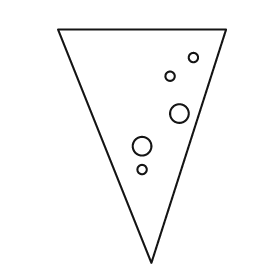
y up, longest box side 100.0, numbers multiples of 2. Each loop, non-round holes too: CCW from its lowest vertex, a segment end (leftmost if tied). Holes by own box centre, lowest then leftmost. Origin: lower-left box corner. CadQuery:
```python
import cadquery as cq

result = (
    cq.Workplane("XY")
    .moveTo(40.0, 0.0)
    .lineTo(72.0, 100.0)
    .lineTo(0.0, 100.0)
    .close()
    .moveTo(36.0, 40.0)
    .circle(2.0)
    .moveTo(36.0, 50.0)
    .circle(4.0)
    .moveTo(52.0, 64.0)
    .circle(4.0)
    .moveTo(48.0, 80.0)
    .circle(2.0)
    .moveTo(58.0, 88.0)
    .circle(2.0)
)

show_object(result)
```